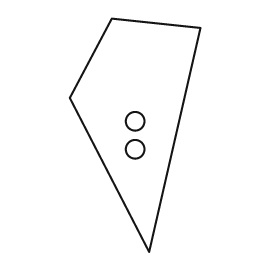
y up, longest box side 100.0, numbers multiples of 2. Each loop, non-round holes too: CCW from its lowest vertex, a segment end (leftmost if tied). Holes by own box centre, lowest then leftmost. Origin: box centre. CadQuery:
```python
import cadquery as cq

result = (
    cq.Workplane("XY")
    .moveTo(6.0, -50.0)
    .lineTo(28.0, 46.0)
    .lineTo(-10.0, 50.0)
    .lineTo(-28.0, 16.0)
    .close()
    .moveTo(0.0, -6.0)
    .circle(4.0)
    .moveTo(0.0, 6.0)
    .circle(4.0)
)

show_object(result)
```